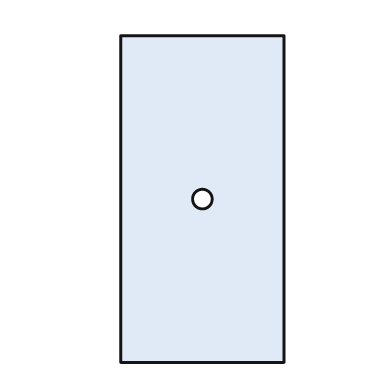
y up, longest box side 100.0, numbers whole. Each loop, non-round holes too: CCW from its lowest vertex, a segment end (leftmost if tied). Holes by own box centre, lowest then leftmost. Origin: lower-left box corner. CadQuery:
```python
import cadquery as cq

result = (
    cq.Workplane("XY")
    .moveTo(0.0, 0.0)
    .lineTo(50.0, 0.0)
    .lineTo(50.0, 100.0)
    .lineTo(0.0, 100.0)
    .close()
    .moveTo(25.0, 50.0)
    .circle(3.0)
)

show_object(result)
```